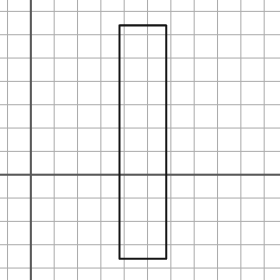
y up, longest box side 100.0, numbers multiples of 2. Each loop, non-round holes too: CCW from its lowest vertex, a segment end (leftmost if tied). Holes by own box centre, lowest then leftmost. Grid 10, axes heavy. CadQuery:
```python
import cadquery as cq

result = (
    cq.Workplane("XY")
    .moveTo(38.0, -36.0)
    .lineTo(58.0, -36.0)
    .lineTo(58.0, 64.0)
    .lineTo(38.0, 64.0)
    .close()
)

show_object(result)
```